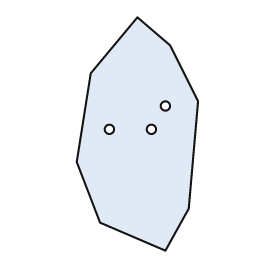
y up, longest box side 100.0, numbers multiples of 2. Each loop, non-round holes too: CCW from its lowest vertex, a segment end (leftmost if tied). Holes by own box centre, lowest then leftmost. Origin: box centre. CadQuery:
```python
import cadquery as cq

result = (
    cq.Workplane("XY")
    .moveTo(12.0, -50.0)
    .lineTo(22.0, -32.0)
    .lineTo(26.0, 14.0)
    .lineTo(14.0, 38.0)
    .lineTo(0.0, 50.0)
    .lineTo(-20.0, 26.0)
    .lineTo(-26.0, -12.0)
    .lineTo(-16.0, -38.0)
    .close()
    .moveTo(-12.0, 2.0)
    .circle(2.0)
    .moveTo(6.0, 2.0)
    .circle(2.0)
    .moveTo(12.0, 12.0)
    .circle(2.0)
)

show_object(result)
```